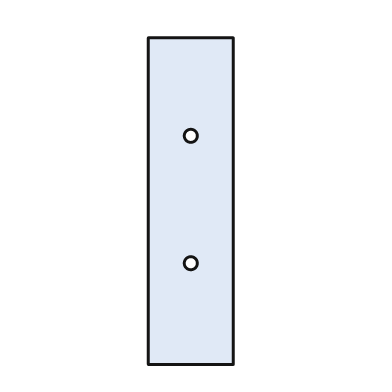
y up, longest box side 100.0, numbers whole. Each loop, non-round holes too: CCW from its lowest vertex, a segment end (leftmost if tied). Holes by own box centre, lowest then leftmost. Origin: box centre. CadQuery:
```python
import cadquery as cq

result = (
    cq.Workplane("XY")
    .moveTo(-13.0, -50.0)
    .lineTo(13.0, -50.0)
    .lineTo(13.0, 50.0)
    .lineTo(-13.0, 50.0)
    .close()
    .moveTo(0.0, -19.0)
    .circle(2.0)
    .moveTo(0.0, 20.0)
    .circle(2.0)
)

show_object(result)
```